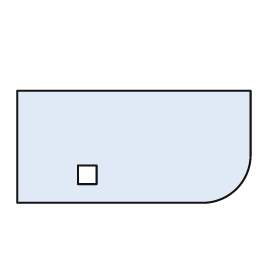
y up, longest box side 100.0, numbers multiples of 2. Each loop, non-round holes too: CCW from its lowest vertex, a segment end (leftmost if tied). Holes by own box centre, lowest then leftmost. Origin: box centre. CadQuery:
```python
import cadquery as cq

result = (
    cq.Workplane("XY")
    .moveTo(-50.0, -24.0)
    .lineTo(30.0, -24.0)
    .threePointArc((44.0, -18.0), (50.0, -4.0))
    .lineTo(50.0, 24.0)
    .lineTo(-50.0, 24.0)
    .close()
    .moveTo(-24.0, -16.0)
    .lineTo(-16.0, -16.0)
    .lineTo(-16.0, -8.0)
    .lineTo(-24.0, -8.0)
    .close()
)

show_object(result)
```